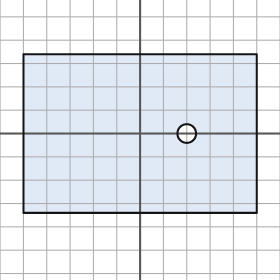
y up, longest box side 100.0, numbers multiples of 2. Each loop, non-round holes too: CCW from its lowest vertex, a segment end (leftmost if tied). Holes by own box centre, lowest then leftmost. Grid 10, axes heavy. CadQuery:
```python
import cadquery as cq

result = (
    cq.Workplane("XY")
    .moveTo(-50.0, -34.0)
    .lineTo(50.0, -34.0)
    .lineTo(50.0, 34.0)
    .lineTo(-50.0, 34.0)
    .close()
    .moveTo(20.0, 0.0)
    .circle(4.0)
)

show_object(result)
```